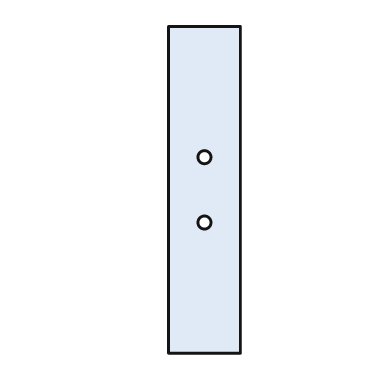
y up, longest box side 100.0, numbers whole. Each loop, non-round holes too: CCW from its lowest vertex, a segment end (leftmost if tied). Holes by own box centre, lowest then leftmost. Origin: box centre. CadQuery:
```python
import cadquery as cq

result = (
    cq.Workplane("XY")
    .moveTo(-11.0, -50.0)
    .lineTo(11.0, -50.0)
    .lineTo(11.0, 50.0)
    .lineTo(-11.0, 50.0)
    .close()
    .moveTo(0.0, -10.0)
    .circle(2.0)
    .moveTo(0.0, 10.0)
    .circle(2.0)
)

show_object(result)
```